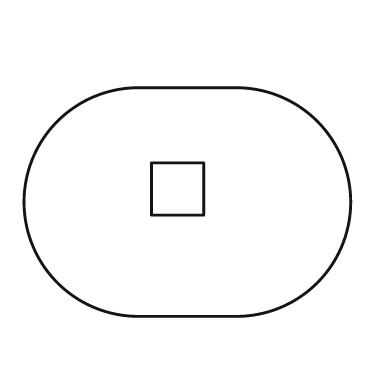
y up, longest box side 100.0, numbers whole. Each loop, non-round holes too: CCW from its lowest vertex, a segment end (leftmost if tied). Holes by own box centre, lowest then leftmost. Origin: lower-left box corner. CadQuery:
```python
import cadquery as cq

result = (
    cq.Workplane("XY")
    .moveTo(35.0, 0.0)
    .lineTo(65.0, 0.0)
    .threePointArc((100.0, 35.0), (65.0, 70.0))
    .lineTo(35.0, 70.0)
    .threePointArc((0.0, 35.0), (35.0, 0.0))
    .close()
    .moveTo(39.0, 31.0)
    .lineTo(55.0, 31.0)
    .lineTo(55.0, 47.0)
    .lineTo(39.0, 47.0)
    .close()
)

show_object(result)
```